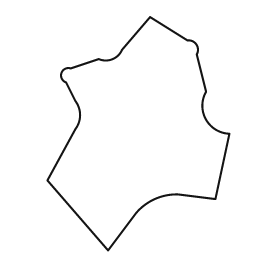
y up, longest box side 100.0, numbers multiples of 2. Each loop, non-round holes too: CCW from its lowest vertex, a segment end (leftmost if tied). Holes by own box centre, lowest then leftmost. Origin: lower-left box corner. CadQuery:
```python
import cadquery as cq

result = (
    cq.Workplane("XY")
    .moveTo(26.0, 0.0)
    .lineTo(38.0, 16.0)
    .threePointArc((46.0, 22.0), (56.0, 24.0))
    .lineTo(72.0, 22.0)
    .lineTo(78.0, 50.0)
    .threePointArc((68.0, 56.0), (68.0, 68.0))
    .lineTo(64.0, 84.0)
    .threePointArc((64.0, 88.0), (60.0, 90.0))
    .lineTo(44.0, 100.0)
    .lineTo(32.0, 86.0)
    .threePointArc((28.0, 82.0), (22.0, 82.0))
    .lineTo(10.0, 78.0)
    .threePointArc((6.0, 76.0), (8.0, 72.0))
    .lineTo(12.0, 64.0)
    .threePointArc((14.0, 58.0), (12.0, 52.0))
    .lineTo(0.0, 30.0)
    .close()
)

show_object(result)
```